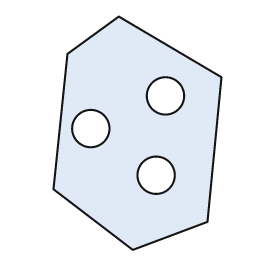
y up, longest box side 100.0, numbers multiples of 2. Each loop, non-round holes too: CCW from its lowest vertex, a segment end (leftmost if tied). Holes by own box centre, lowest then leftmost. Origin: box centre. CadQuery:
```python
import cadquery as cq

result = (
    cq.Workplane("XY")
    .moveTo(-2.0, -50.0)
    .lineTo(30.0, -38.0)
    .lineTo(36.0, 24.0)
    .lineTo(-8.0, 50.0)
    .lineTo(-30.0, 34.0)
    .lineTo(-36.0, -24.0)
    .close()
    .moveTo(8.0, -18.0)
    .circle(8.0)
    .moveTo(-20.0, 2.0)
    .circle(8.0)
    .moveTo(12.0, 16.0)
    .circle(8.0)
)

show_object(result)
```